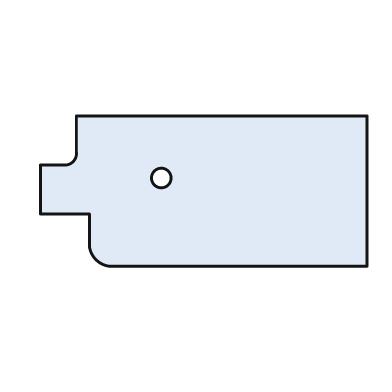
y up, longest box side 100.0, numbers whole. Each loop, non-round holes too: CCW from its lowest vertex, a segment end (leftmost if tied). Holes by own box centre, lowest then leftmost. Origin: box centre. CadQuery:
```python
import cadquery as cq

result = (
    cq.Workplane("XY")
    .moveTo(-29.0, -23.0)
    .lineTo(50.0, -23.0)
    .lineTo(50.0, 23.0)
    .lineTo(-39.0, 23.0)
    .lineTo(-39.0, 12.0)
    .threePointArc((-40.0, 9.0), (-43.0, 8.0))
    .lineTo(-50.0, 8.0)
    .lineTo(-50.0, -7.0)
    .lineTo(-35.0, -7.0)
    .lineTo(-35.0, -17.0)
    .threePointArc((-33.0, -21.0), (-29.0, -23.0))
    .close()
    .moveTo(-13.0, 4.0)
    .circle(3.0)
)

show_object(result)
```